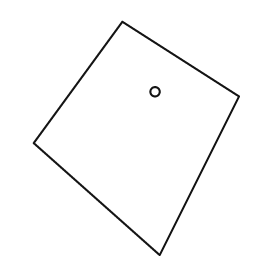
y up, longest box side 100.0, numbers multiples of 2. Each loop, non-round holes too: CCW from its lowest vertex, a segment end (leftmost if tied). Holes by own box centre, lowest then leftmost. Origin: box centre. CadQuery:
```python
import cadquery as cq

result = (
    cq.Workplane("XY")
    .moveTo(10.0, -50.0)
    .lineTo(44.0, 18.0)
    .lineTo(-6.0, 50.0)
    .lineTo(-44.0, -2.0)
    .close()
    .moveTo(8.0, 20.0)
    .circle(2.0)
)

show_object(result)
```